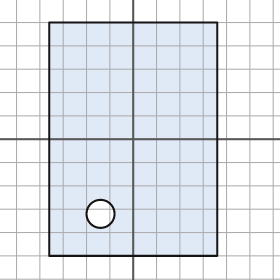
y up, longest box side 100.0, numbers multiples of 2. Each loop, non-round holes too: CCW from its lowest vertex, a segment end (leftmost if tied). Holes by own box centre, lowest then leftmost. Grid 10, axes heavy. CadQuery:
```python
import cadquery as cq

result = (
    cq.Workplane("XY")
    .moveTo(-36.0, -50.0)
    .lineTo(36.0, -50.0)
    .lineTo(36.0, 50.0)
    .lineTo(-36.0, 50.0)
    .close()
    .moveTo(-14.0, -32.0)
    .circle(6.0)
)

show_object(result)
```